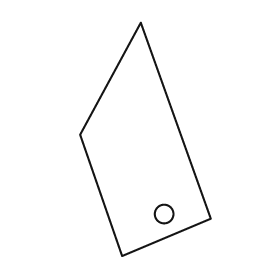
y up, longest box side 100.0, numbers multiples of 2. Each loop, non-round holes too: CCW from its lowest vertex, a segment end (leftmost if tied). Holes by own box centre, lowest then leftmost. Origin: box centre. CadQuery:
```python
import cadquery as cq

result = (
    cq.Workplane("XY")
    .moveTo(-10.0, -50.0)
    .lineTo(28.0, -34.0)
    .lineTo(-2.0, 50.0)
    .lineTo(-28.0, 2.0)
    .close()
    .moveTo(8.0, -32.0)
    .circle(4.0)
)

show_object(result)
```